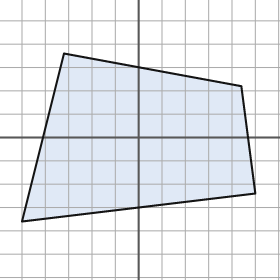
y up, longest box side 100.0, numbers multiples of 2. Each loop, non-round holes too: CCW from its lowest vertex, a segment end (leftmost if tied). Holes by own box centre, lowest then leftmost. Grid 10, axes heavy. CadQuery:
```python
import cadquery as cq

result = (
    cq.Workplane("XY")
    .moveTo(-50.0, -36.0)
    .lineTo(50.0, -24.0)
    .lineTo(44.0, 22.0)
    .lineTo(-32.0, 36.0)
    .close()
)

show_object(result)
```